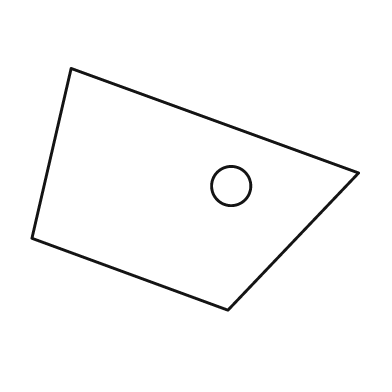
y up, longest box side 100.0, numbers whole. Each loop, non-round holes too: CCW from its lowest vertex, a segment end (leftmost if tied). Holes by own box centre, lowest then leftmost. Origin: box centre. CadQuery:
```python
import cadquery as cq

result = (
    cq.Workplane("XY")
    .moveTo(10.0, -37.0)
    .lineTo(50.0, 5.0)
    .lineTo(-38.0, 37.0)
    .lineTo(-50.0, -15.0)
    .close()
    .moveTo(11.0, 1.0)
    .circle(6.0)
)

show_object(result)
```